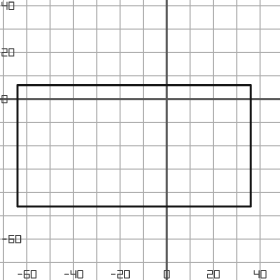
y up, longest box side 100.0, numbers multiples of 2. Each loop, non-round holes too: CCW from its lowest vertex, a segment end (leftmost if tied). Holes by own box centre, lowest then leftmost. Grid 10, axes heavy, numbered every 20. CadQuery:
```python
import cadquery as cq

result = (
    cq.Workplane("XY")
    .moveTo(-64.0, -46.0)
    .lineTo(36.0, -46.0)
    .lineTo(36.0, 6.0)
    .lineTo(-64.0, 6.0)
    .close()
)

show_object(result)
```